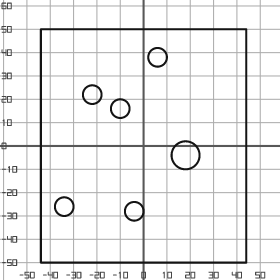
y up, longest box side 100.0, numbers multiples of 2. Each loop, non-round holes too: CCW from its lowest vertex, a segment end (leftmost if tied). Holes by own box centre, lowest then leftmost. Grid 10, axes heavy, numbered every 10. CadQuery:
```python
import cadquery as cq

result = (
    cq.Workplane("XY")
    .moveTo(-44.0, -50.0)
    .lineTo(44.0, -50.0)
    .lineTo(44.0, 50.0)
    .lineTo(-44.0, 50.0)
    .close()
    .moveTo(-4.0, -28.0)
    .circle(4.0)
    .moveTo(-34.0, -26.0)
    .circle(4.0)
    .moveTo(18.0, -4.0)
    .circle(6.0)
    .moveTo(-10.0, 16.0)
    .circle(4.0)
    .moveTo(-22.0, 22.0)
    .circle(4.0)
    .moveTo(6.0, 38.0)
    .circle(4.0)
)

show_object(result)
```